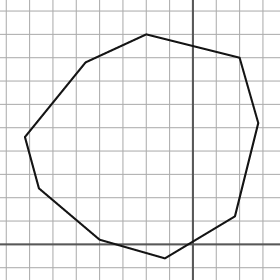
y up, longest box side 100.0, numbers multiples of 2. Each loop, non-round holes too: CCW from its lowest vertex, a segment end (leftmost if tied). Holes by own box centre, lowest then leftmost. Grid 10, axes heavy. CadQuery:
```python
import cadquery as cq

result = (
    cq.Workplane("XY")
    .moveTo(-12.0, -6.0)
    .lineTo(18.0, 12.0)
    .lineTo(28.0, 52.0)
    .lineTo(20.0, 80.0)
    .lineTo(-20.0, 90.0)
    .lineTo(-46.0, 78.0)
    .lineTo(-72.0, 46.0)
    .lineTo(-66.0, 24.0)
    .lineTo(-40.0, 2.0)
    .close()
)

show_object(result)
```